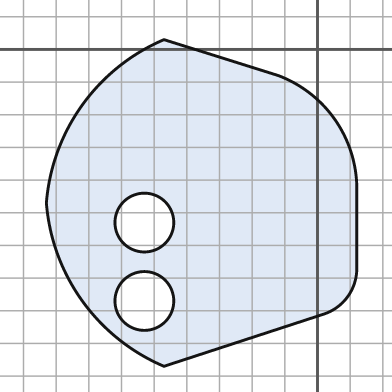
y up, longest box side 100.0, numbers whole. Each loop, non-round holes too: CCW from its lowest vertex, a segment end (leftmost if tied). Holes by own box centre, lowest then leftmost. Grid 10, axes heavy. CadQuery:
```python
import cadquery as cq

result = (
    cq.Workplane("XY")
    .moveTo(-47.0, -97.0)
    .lineTo(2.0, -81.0)
    .threePointArc((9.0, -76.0), (12.0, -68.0))
    .lineTo(12.0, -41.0)
    .threePointArc((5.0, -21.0), (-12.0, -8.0))
    .lineTo(-47.0, 3.0)
    .threePointArc((-72.0, -17.0), (-83.0, -47.0))
    .threePointArc((-72.0, -77.0), (-47.0, -97.0))
    .close()
    .moveTo(-53.0, -77.0)
    .circle(9.0)
    .moveTo(-53.0, -53.0)
    .circle(9.0)
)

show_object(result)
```